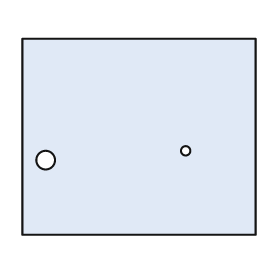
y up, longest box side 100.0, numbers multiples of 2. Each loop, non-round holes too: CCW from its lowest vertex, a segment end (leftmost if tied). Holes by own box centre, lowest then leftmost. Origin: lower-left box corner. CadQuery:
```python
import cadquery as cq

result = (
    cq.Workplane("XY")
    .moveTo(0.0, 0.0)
    .lineTo(100.0, 0.0)
    .lineTo(100.0, 84.0)
    .lineTo(0.0, 84.0)
    .close()
    .moveTo(10.0, 32.0)
    .circle(4.0)
    .moveTo(70.0, 36.0)
    .circle(2.0)
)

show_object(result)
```